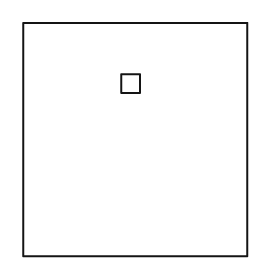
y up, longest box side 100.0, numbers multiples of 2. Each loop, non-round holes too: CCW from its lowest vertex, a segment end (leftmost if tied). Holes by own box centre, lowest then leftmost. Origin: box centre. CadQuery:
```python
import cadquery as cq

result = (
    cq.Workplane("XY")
    .moveTo(-48.0, -50.0)
    .lineTo(48.0, -50.0)
    .lineTo(48.0, 50.0)
    .lineTo(-48.0, 50.0)
    .close()
    .moveTo(-6.0, 20.0)
    .lineTo(2.0, 20.0)
    .lineTo(2.0, 28.0)
    .lineTo(-6.0, 28.0)
    .close()
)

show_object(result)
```